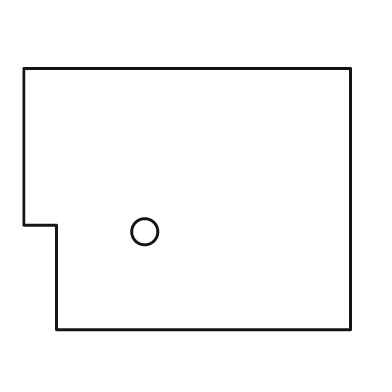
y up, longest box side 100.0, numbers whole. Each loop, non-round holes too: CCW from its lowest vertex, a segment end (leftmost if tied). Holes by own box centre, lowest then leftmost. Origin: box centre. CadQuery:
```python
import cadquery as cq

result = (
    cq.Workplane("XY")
    .moveTo(-40.0, -40.0)
    .lineTo(50.0, -40.0)
    .lineTo(50.0, 40.0)
    .lineTo(-50.0, 40.0)
    .lineTo(-50.0, -8.0)
    .lineTo(-40.0, -8.0)
    .close()
    .moveTo(-13.0, -10.0)
    .circle(4.0)
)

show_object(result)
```